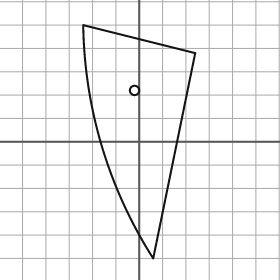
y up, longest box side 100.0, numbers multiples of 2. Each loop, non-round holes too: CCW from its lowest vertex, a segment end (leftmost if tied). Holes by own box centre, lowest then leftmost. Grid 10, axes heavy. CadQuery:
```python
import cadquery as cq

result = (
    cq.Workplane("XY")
    .moveTo(6.0, -50.0)
    .lineTo(24.0, 38.0)
    .lineTo(-24.0, 50.0)
    .threePointArc((-16.0, -2.0), (6.0, -50.0))
    .close()
    .moveTo(-2.0, 22.0)
    .circle(2.0)
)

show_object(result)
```